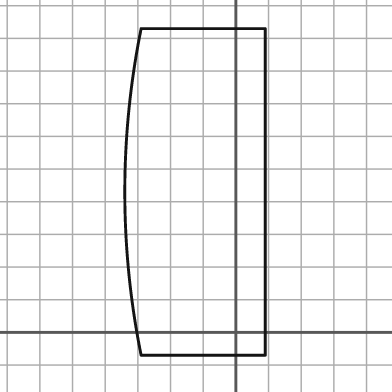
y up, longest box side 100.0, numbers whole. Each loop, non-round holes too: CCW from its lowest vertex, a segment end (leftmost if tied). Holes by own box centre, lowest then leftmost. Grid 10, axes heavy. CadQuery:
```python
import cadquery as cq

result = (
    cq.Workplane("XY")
    .moveTo(-29.0, -7.0)
    .lineTo(9.0, -7.0)
    .lineTo(9.0, 93.0)
    .lineTo(-29.0, 93.0)
    .threePointArc((-34.0, 43.0), (-29.0, -7.0))
    .close()
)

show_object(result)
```